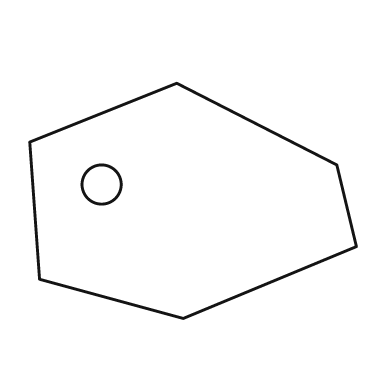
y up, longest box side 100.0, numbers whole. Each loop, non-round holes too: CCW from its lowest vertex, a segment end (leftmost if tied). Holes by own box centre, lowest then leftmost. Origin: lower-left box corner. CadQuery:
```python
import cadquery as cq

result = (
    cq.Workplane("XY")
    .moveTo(47.0, 0.0)
    .lineTo(100.0, 22.0)
    .lineTo(94.0, 47.0)
    .lineTo(45.0, 72.0)
    .lineTo(0.0, 54.0)
    .lineTo(3.0, 12.0)
    .close()
    .moveTo(22.0, 41.0)
    .circle(6.0)
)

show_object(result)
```